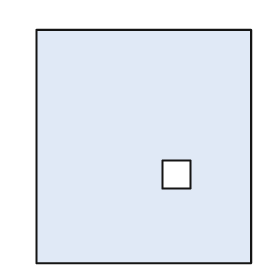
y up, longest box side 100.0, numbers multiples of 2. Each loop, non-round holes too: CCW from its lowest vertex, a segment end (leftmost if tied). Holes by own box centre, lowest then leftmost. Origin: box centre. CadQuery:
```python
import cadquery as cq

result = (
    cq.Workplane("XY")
    .moveTo(-46.0, -50.0)
    .lineTo(46.0, -50.0)
    .lineTo(46.0, 50.0)
    .lineTo(-46.0, 50.0)
    .close()
    .moveTo(8.0, -18.0)
    .lineTo(20.0, -18.0)
    .lineTo(20.0, -6.0)
    .lineTo(8.0, -6.0)
    .close()
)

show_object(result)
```